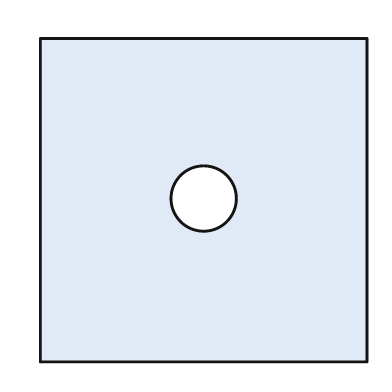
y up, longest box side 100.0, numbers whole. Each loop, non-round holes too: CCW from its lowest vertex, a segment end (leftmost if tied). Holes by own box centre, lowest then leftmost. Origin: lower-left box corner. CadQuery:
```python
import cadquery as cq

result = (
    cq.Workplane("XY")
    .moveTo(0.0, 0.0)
    .lineTo(100.0, 0.0)
    .lineTo(100.0, 99.0)
    .lineTo(0.0, 99.0)
    .close()
    .moveTo(50.0, 50.0)
    .circle(10.0)
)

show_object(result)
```